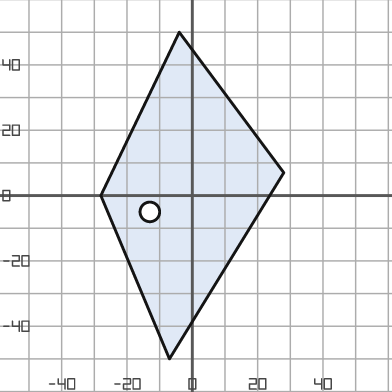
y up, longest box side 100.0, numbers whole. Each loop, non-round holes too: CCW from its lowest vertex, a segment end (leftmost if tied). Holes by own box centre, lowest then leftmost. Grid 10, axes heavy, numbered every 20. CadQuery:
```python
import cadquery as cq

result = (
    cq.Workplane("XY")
    .moveTo(-7.0, -50.0)
    .lineTo(28.0, 7.0)
    .lineTo(-4.0, 50.0)
    .lineTo(-28.0, 0.0)
    .close()
    .moveTo(-13.0, -5.0)
    .circle(3.0)
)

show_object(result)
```